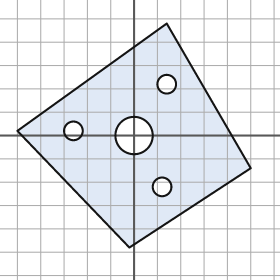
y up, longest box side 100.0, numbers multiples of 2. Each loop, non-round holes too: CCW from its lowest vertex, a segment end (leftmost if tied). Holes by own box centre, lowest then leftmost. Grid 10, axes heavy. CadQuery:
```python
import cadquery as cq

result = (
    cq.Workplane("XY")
    .moveTo(-2.0, -48.0)
    .lineTo(50.0, -14.0)
    .lineTo(14.0, 48.0)
    .lineTo(-50.0, 2.0)
    .close()
    .moveTo(12.0, -22.0)
    .circle(4.0)
    .moveTo(0.0, 0.0)
    .circle(8.0)
    .moveTo(-26.0, 2.0)
    .circle(4.0)
    .moveTo(14.0, 22.0)
    .circle(4.0)
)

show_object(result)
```